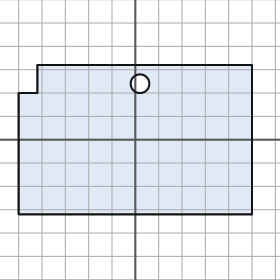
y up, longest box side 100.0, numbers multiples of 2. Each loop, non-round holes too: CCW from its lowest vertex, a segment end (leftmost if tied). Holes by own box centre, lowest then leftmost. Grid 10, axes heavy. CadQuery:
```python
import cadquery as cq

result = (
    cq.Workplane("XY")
    .moveTo(-50.0, -32.0)
    .lineTo(50.0, -32.0)
    .lineTo(50.0, 32.0)
    .lineTo(-42.0, 32.0)
    .lineTo(-42.0, 20.0)
    .lineTo(-50.0, 20.0)
    .close()
    .moveTo(2.0, 24.0)
    .circle(4.0)
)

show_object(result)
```